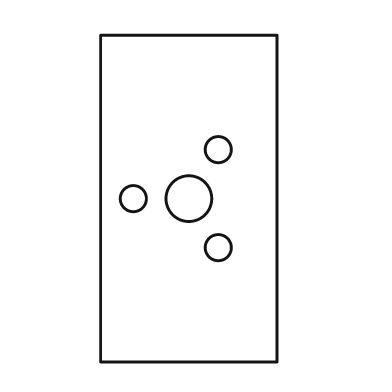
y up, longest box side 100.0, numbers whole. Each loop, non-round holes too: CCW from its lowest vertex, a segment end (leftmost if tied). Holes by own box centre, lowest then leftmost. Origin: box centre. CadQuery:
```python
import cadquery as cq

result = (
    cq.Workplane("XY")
    .moveTo(-27.0, -50.0)
    .lineTo(27.0, -50.0)
    .lineTo(27.0, 50.0)
    .lineTo(-27.0, 50.0)
    .close()
    .moveTo(9.0, -15.0)
    .circle(4.0)
    .moveTo(-17.0, 0.0)
    .circle(4.0)
    .moveTo(0.0, 0.0)
    .circle(7.0)
    .moveTo(9.0, 15.0)
    .circle(4.0)
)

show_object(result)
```